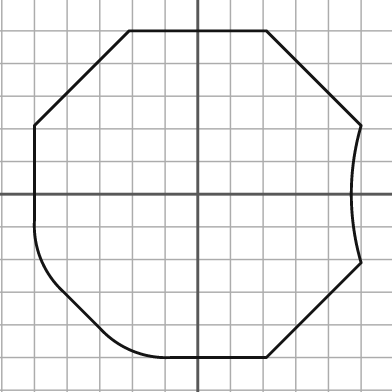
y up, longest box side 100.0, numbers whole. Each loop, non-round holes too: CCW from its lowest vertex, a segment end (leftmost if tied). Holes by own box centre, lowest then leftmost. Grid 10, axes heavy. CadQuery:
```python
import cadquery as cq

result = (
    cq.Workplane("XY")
    .moveTo(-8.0, -50.0)
    .lineTo(21.0, -50.0)
    .lineTo(50.0, -21.0)
    .threePointArc((47.0, 0.0), (50.0, 21.0))
    .lineTo(21.0, 50.0)
    .lineTo(-21.0, 50.0)
    .lineTo(-50.0, 21.0)
    .lineTo(-50.0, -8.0)
    .threePointArc((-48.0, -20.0), (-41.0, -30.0))
    .lineTo(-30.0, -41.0)
    .threePointArc((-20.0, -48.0), (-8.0, -50.0))
    .close()
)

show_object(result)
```